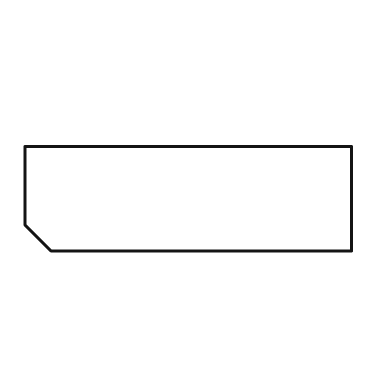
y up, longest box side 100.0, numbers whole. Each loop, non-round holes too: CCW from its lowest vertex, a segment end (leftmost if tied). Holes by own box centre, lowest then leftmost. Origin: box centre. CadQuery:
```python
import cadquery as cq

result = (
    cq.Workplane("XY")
    .moveTo(-42.0, -16.0)
    .lineTo(50.0, -16.0)
    .lineTo(50.0, 16.0)
    .lineTo(-50.0, 16.0)
    .lineTo(-50.0, -8.0)
    .close()
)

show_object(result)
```